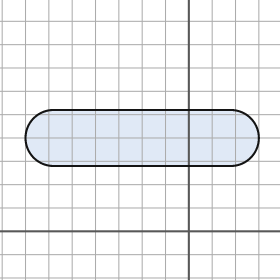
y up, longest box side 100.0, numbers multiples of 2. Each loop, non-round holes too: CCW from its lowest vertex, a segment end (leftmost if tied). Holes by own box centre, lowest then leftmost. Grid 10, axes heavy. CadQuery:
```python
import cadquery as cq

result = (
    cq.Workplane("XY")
    .moveTo(-58.0, 28.0)
    .lineTo(18.0, 28.0)
    .threePointArc((30.0, 40.0), (18.0, 52.0))
    .lineTo(-58.0, 52.0)
    .threePointArc((-70.0, 40.0), (-58.0, 28.0))
    .close()
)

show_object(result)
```